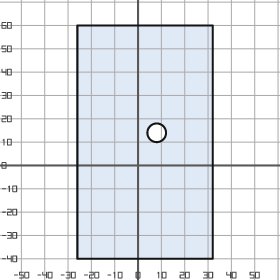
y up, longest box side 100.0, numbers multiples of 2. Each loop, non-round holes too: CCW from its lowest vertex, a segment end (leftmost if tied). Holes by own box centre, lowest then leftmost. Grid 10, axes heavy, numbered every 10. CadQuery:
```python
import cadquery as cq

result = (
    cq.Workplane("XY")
    .moveTo(-26.0, -40.0)
    .lineTo(32.0, -40.0)
    .lineTo(32.0, 60.0)
    .lineTo(-26.0, 60.0)
    .close()
    .moveTo(8.0, 14.0)
    .circle(4.0)
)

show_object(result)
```